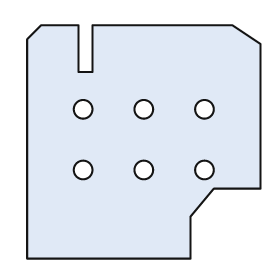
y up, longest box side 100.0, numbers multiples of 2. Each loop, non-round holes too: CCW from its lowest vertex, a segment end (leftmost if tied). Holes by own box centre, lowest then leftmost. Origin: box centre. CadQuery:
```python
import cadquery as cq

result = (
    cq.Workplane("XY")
    .moveTo(-50.0, -50.0)
    .lineTo(20.0, -50.0)
    .lineTo(20.0, -32.0)
    .lineTo(30.0, -20.0)
    .lineTo(50.0, -20.0)
    .lineTo(50.0, 42.0)
    .lineTo(38.0, 50.0)
    .lineTo(-22.0, 50.0)
    .lineTo(-22.0, 30.0)
    .lineTo(-28.0, 30.0)
    .lineTo(-28.0, 50.0)
    .lineTo(-44.0, 50.0)
    .lineTo(-50.0, 44.0)
    .close()
    .moveTo(-26.0, -12.0)
    .circle(4.0)
    .moveTo(0.0, -12.0)
    .circle(4.0)
    .moveTo(26.0, -12.0)
    .circle(4.0)
    .moveTo(-26.0, 14.0)
    .circle(4.0)
    .moveTo(0.0, 14.0)
    .circle(4.0)
    .moveTo(26.0, 14.0)
    .circle(4.0)
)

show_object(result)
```